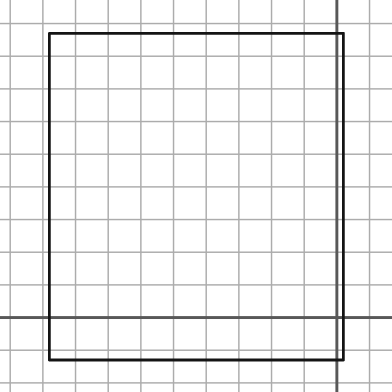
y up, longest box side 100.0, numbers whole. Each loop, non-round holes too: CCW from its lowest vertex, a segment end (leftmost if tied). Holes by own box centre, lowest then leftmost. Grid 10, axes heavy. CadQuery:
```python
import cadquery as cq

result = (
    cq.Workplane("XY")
    .moveTo(-88.0, -13.0)
    .lineTo(2.0, -13.0)
    .lineTo(2.0, 87.0)
    .lineTo(-88.0, 87.0)
    .close()
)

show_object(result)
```